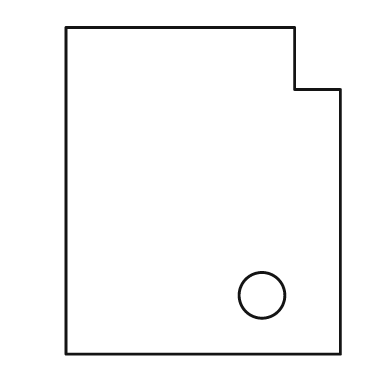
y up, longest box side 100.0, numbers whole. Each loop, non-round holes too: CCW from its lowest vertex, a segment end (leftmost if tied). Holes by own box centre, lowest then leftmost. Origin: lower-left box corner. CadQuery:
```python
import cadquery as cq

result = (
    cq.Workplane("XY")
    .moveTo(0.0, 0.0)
    .lineTo(84.0, 0.0)
    .lineTo(84.0, 81.0)
    .lineTo(70.0, 81.0)
    .lineTo(70.0, 100.0)
    .lineTo(0.0, 100.0)
    .close()
    .moveTo(60.0, 18.0)
    .circle(7.0)
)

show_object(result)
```